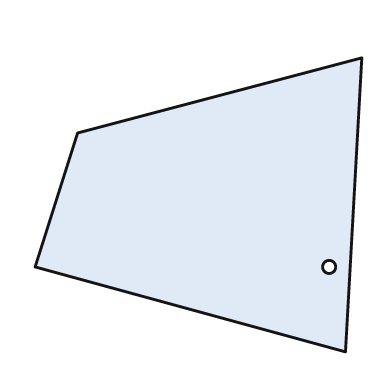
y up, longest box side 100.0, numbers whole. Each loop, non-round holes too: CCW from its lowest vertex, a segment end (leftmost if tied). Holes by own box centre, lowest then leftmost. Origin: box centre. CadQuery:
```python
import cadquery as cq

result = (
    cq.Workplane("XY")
    .moveTo(45.0, -45.0)
    .lineTo(50.0, 45.0)
    .lineTo(-37.0, 22.0)
    .lineTo(-50.0, -19.0)
    .close()
    .moveTo(40.0, -19.0)
    .circle(2.0)
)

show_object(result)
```